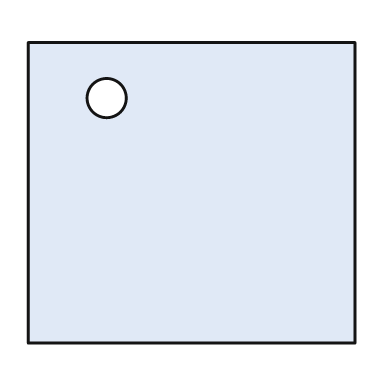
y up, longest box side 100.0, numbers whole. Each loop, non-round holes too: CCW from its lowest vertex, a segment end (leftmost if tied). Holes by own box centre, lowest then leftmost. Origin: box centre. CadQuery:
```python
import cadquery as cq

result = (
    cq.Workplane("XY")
    .moveTo(-50.0, -46.0)
    .lineTo(50.0, -46.0)
    .lineTo(50.0, 46.0)
    .lineTo(-50.0, 46.0)
    .close()
    .moveTo(-26.0, 29.0)
    .circle(6.0)
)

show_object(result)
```